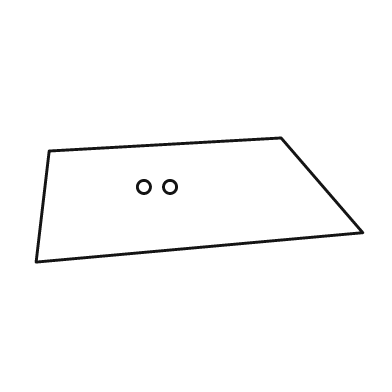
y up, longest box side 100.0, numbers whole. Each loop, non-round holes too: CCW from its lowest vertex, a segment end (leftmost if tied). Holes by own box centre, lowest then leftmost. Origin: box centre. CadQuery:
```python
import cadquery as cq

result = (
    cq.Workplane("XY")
    .moveTo(-50.0, -19.0)
    .lineTo(50.0, -10.0)
    .lineTo(25.0, 19.0)
    .lineTo(-46.0, 15.0)
    .close()
    .moveTo(-17.0, 4.0)
    .circle(2.0)
    .moveTo(-9.0, 4.0)
    .circle(2.0)
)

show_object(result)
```